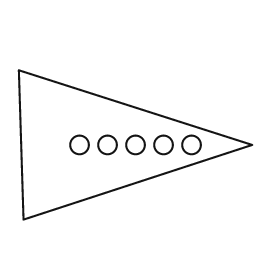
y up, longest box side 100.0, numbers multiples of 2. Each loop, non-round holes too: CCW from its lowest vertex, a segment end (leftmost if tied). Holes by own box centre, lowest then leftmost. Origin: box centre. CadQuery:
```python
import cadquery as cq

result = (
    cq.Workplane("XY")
    .moveTo(-48.0, -32.0)
    .lineTo(50.0, 0.0)
    .lineTo(-50.0, 32.0)
    .close()
    .moveTo(-24.0, 0.0)
    .circle(4.0)
    .moveTo(-12.0, 0.0)
    .circle(4.0)
    .moveTo(0.0, 0.0)
    .circle(4.0)
    .moveTo(12.0, 0.0)
    .circle(4.0)
    .moveTo(24.0, 0.0)
    .circle(4.0)
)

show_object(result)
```